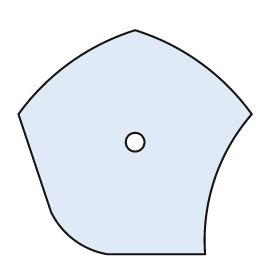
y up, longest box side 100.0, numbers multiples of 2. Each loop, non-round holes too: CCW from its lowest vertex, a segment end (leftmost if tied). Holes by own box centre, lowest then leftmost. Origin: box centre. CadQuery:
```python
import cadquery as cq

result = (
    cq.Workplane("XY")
    .moveTo(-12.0, -48.0)
    .lineTo(30.0, -48.0)
    .threePointArc((34.0, -16.0), (50.0, 12.0))
    .threePointArc((28.0, 34.0), (0.0, 48.0))
    .threePointArc((-28.0, 34.0), (-50.0, 12.0))
    .lineTo(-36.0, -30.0)
    .threePointArc((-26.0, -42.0), (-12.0, -48.0))
    .close()
    .moveTo(0.0, 0.0)
    .circle(4.0)
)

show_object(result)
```